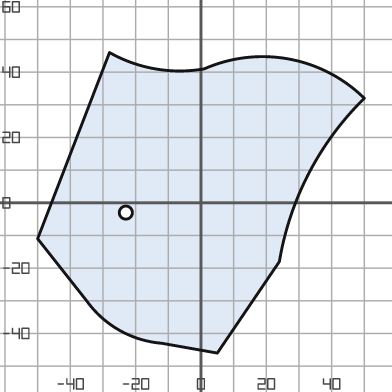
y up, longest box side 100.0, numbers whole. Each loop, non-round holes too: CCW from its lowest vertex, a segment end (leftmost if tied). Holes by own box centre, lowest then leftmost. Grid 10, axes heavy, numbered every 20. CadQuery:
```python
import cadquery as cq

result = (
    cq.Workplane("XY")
    .moveTo(5.0, -46.0)
    .lineTo(24.0, -18.0)
    .threePointArc((33.0, 9.0), (50.0, 32.0))
    .threePointArc((27.0, 44.0), (1.0, 41.0))
    .threePointArc((-14.0, 41.0), (-28.0, 46.0))
    .lineTo(-50.0, -11.0)
    .lineTo(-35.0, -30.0)
    .threePointArc((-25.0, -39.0), (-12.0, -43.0))
    .close()
    .moveTo(-23.0, -3.0)
    .circle(2.0)
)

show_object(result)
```